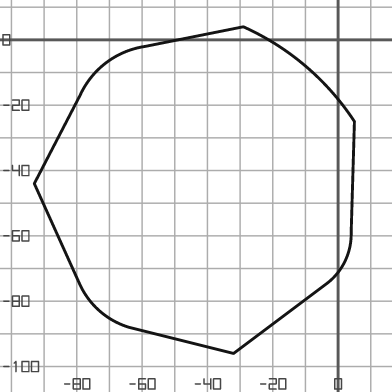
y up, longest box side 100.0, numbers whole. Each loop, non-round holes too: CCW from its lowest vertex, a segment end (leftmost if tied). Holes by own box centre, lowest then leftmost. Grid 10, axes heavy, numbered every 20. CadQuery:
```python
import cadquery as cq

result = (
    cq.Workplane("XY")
    .moveTo(-32.0, -96.0)
    .lineTo(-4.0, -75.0)
    .threePointArc((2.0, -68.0), (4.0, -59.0))
    .lineTo(5.0, -25.0)
    .threePointArc((-10.0, -8.0), (-29.0, 4.0))
    .lineTo(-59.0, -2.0)
    .threePointArc((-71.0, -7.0), (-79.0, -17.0))
    .lineTo(-93.0, -44.0)
    .lineTo(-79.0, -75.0)
    .threePointArc((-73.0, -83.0), (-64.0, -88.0))
    .close()
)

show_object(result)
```